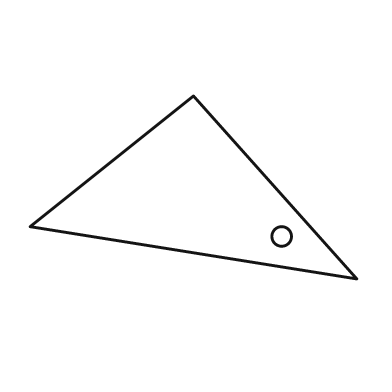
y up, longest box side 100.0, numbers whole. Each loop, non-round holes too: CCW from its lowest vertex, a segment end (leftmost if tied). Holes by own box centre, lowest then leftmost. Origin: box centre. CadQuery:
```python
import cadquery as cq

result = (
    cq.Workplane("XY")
    .moveTo(50.0, -28.0)
    .lineTo(0.0, 28.0)
    .lineTo(-50.0, -12.0)
    .close()
    .moveTo(27.0, -15.0)
    .circle(3.0)
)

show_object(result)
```